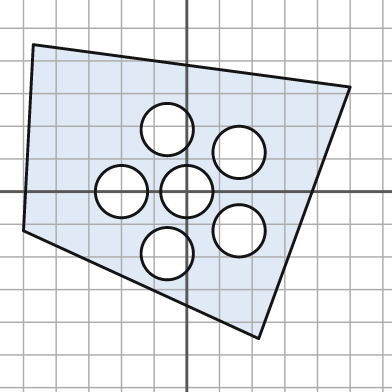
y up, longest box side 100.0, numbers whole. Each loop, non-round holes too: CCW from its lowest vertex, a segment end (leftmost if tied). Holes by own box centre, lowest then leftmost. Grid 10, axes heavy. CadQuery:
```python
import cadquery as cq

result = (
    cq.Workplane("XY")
    .moveTo(22.0, -45.0)
    .lineTo(50.0, 32.0)
    .lineTo(-47.0, 45.0)
    .lineTo(-50.0, -12.0)
    .close()
    .moveTo(-6.0, -19.0)
    .circle(8.0)
    .moveTo(16.0, -12.0)
    .circle(8.0)
    .moveTo(-20.0, 0.0)
    .circle(8.0)
    .moveTo(0.0, 0.0)
    .circle(8.0)
    .moveTo(16.0, 12.0)
    .circle(8.0)
    .moveTo(-6.0, 19.0)
    .circle(8.0)
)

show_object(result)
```